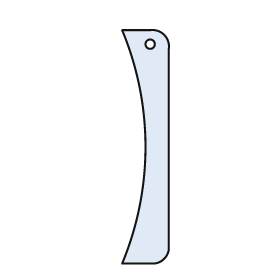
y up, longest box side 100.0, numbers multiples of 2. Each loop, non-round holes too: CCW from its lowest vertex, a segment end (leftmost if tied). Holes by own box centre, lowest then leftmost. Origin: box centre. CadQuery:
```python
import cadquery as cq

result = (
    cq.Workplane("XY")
    .moveTo(-10.0, -50.0)
    .lineTo(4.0, -50.0)
    .threePointArc((8.0, -48.0), (10.0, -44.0))
    .lineTo(10.0, 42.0)
    .threePointArc((8.0, 48.0), (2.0, 50.0))
    .lineTo(-10.0, 50.0)
    .threePointArc((0.0, 0.0), (-10.0, -50.0))
    .close()
    .moveTo(2.0, 44.0)
    .circle(2.0)
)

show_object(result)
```